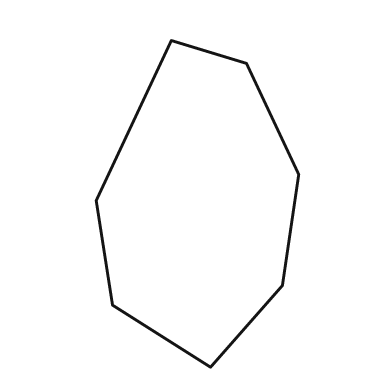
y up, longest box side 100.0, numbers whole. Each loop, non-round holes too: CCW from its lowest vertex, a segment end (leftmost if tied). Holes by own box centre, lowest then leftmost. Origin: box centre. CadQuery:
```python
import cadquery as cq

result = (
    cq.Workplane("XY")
    .moveTo(4.0, -50.0)
    .lineTo(26.0, -25.0)
    .lineTo(31.0, 9.0)
    .lineTo(15.0, 43.0)
    .lineTo(-8.0, 50.0)
    .lineTo(-31.0, 1.0)
    .lineTo(-26.0, -31.0)
    .close()
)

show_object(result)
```